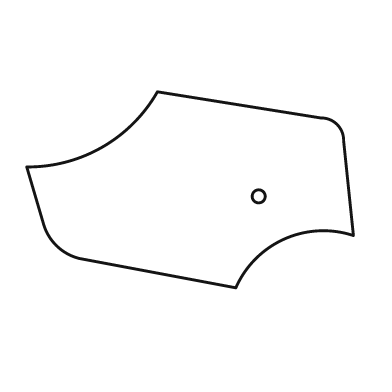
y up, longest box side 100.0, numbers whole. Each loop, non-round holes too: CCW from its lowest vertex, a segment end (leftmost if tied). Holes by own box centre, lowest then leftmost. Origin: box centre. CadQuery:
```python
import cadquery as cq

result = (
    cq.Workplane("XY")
    .moveTo(14.0, -30.0)
    .threePointArc((29.0, -15.0), (50.0, -14.0))
    .lineTo(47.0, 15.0)
    .threePointArc((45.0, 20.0), (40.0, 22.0))
    .lineTo(-10.0, 30.0)
    .threePointArc((-27.0, 13.0), (-50.0, 7.0))
    .lineTo(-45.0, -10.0)
    .threePointArc((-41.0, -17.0), (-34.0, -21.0))
    .close()
    .moveTo(21.0, -2.0)
    .circle(2.0)
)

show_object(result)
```